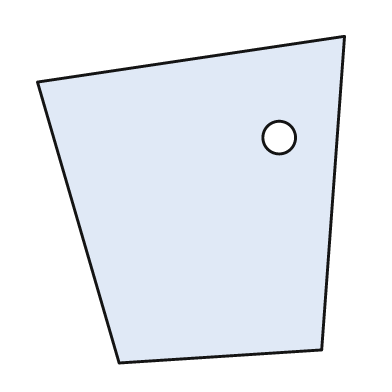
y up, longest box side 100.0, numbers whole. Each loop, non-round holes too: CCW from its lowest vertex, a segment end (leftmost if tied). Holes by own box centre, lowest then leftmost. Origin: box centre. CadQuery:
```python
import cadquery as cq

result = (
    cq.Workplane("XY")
    .moveTo(-22.0, -50.0)
    .lineTo(40.0, -46.0)
    .lineTo(47.0, 50.0)
    .lineTo(-47.0, 36.0)
    .close()
    .moveTo(27.0, 19.0)
    .circle(5.0)
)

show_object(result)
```